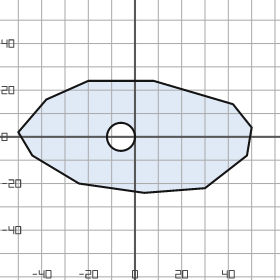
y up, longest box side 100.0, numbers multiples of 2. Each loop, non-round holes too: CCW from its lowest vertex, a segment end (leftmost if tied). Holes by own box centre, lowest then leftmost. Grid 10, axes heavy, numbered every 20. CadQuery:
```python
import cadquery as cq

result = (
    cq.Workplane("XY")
    .moveTo(4.0, -24.0)
    .lineTo(30.0, -22.0)
    .lineTo(48.0, -8.0)
    .lineTo(50.0, 4.0)
    .lineTo(42.0, 14.0)
    .lineTo(8.0, 24.0)
    .lineTo(-20.0, 24.0)
    .lineTo(-38.0, 16.0)
    .lineTo(-50.0, 2.0)
    .lineTo(-44.0, -8.0)
    .lineTo(-24.0, -20.0)
    .close()
    .moveTo(-6.0, 0.0)
    .circle(6.0)
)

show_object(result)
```